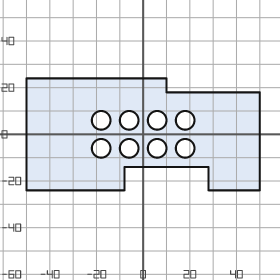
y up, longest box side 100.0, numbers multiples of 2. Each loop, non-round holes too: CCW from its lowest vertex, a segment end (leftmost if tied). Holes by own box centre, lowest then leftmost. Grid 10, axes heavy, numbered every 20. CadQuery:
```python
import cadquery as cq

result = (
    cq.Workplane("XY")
    .moveTo(-50.0, -24.0)
    .lineTo(-8.0, -24.0)
    .lineTo(-8.0, -14.0)
    .lineTo(28.0, -14.0)
    .lineTo(28.0, -24.0)
    .lineTo(50.0, -24.0)
    .lineTo(50.0, 18.0)
    .lineTo(10.0, 18.0)
    .lineTo(10.0, 24.0)
    .lineTo(-50.0, 24.0)
    .close()
    .moveTo(-18.0, -6.0)
    .circle(4.0)
    .moveTo(-6.0, -6.0)
    .circle(4.0)
    .moveTo(6.0, -6.0)
    .circle(4.0)
    .moveTo(18.0, -6.0)
    .circle(4.0)
    .moveTo(-18.0, 6.0)
    .circle(4.0)
    .moveTo(-6.0, 6.0)
    .circle(4.0)
    .moveTo(6.0, 6.0)
    .circle(4.0)
    .moveTo(18.0, 6.0)
    .circle(4.0)
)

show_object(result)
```